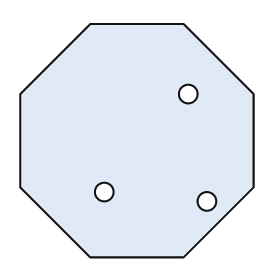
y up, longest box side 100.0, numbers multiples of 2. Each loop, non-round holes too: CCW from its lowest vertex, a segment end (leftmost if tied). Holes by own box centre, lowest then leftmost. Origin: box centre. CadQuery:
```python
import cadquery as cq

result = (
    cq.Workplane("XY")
    .moveTo(-20.0, -50.0)
    .lineTo(20.0, -50.0)
    .lineTo(50.0, -20.0)
    .lineTo(50.0, 20.0)
    .lineTo(20.0, 50.0)
    .lineTo(-20.0, 50.0)
    .lineTo(-50.0, 20.0)
    .lineTo(-50.0, -20.0)
    .close()
    .moveTo(30.0, -26.0)
    .circle(4.0)
    .moveTo(-14.0, -22.0)
    .circle(4.0)
    .moveTo(22.0, 20.0)
    .circle(4.0)
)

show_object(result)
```